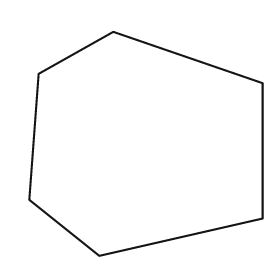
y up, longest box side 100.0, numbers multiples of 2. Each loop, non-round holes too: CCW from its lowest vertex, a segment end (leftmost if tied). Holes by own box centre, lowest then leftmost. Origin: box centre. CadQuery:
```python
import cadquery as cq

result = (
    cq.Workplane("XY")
    .moveTo(-20.0, -48.0)
    .lineTo(50.0, -32.0)
    .lineTo(50.0, 26.0)
    .lineTo(-14.0, 48.0)
    .lineTo(-46.0, 30.0)
    .lineTo(-50.0, -24.0)
    .close()
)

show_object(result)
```